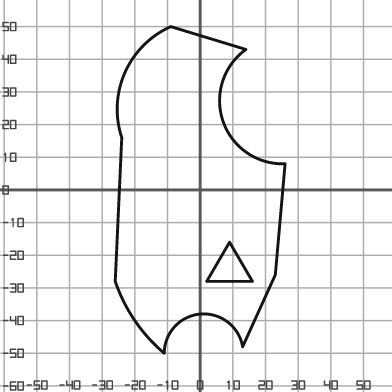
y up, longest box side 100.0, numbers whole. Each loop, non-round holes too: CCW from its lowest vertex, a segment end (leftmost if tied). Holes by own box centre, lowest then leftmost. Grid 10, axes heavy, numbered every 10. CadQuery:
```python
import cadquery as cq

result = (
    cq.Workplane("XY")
    .moveTo(-11.0, -50.0)
    .threePointArc((0.0, -38.0), (13.0, -48.0))
    .lineTo(23.0, -26.0)
    .lineTo(26.0, 8.0)
    .threePointArc((7.0, 21.0), (14.0, 43.0))
    .lineTo(-9.0, 50.0)
    .threePointArc((-23.0, 36.0), (-24.0, 16.0))
    .lineTo(-26.0, -28.0)
    .threePointArc((-20.0, -40.0), (-11.0, -50.0))
    .close()
    .moveTo(2.0, -28.0)
    .lineTo(16.0, -28.0)
    .lineTo(9.0, -16.0)
    .close()
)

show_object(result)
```